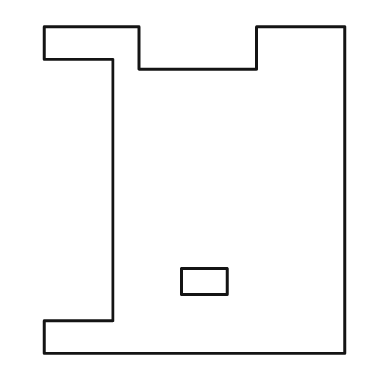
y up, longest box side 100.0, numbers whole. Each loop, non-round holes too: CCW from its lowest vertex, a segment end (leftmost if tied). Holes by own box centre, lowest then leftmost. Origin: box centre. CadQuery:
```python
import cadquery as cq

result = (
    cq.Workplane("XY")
    .moveTo(-46.0, -50.0)
    .lineTo(46.0, -50.0)
    .lineTo(46.0, 50.0)
    .lineTo(19.0, 50.0)
    .lineTo(19.0, 37.0)
    .lineTo(-17.0, 37.0)
    .lineTo(-17.0, 50.0)
    .lineTo(-46.0, 50.0)
    .lineTo(-46.0, 40.0)
    .lineTo(-25.0, 40.0)
    .lineTo(-25.0, -40.0)
    .lineTo(-46.0, -40.0)
    .close()
    .moveTo(-4.0, -32.0)
    .lineTo(10.0, -32.0)
    .lineTo(10.0, -24.0)
    .lineTo(-4.0, -24.0)
    .close()
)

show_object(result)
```